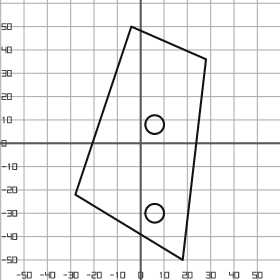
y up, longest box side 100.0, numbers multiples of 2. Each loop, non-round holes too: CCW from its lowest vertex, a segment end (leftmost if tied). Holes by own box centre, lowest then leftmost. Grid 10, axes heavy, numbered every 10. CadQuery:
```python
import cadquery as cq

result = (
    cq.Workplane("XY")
    .moveTo(18.0, -50.0)
    .lineTo(28.0, 36.0)
    .lineTo(-4.0, 50.0)
    .lineTo(-28.0, -22.0)
    .close()
    .moveTo(6.0, -30.0)
    .circle(4.0)
    .moveTo(6.0, 8.0)
    .circle(4.0)
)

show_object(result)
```